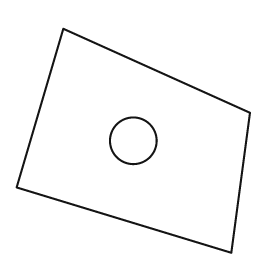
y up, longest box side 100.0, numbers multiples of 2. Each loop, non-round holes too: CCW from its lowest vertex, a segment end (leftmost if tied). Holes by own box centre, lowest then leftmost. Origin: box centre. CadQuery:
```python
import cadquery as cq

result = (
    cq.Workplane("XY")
    .moveTo(42.0, -48.0)
    .lineTo(50.0, 12.0)
    .lineTo(-30.0, 48.0)
    .lineTo(-50.0, -20.0)
    .close()
    .moveTo(0.0, 0.0)
    .circle(10.0)
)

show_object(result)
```